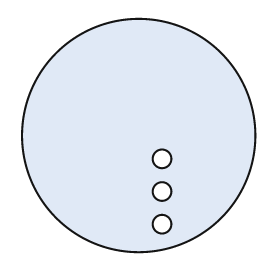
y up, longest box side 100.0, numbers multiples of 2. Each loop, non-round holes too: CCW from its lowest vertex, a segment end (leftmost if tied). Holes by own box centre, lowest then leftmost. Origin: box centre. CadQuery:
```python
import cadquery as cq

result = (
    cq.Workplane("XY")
    .moveTo(0.0, 0.0)
    .circle(50.0)
    .moveTo(10.0, -38.0)
    .circle(4.0)
    .moveTo(10.0, -24.0)
    .circle(4.0)
    .moveTo(10.0, -10.0)
    .circle(4.0)
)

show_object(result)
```